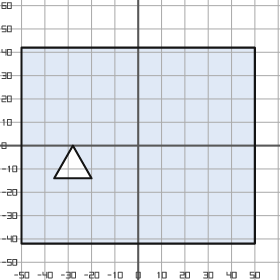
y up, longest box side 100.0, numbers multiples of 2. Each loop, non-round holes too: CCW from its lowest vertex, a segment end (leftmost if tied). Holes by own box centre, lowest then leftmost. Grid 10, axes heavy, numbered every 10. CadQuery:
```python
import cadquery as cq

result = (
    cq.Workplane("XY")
    .moveTo(-50.0, -42.0)
    .lineTo(50.0, -42.0)
    .lineTo(50.0, 42.0)
    .lineTo(-50.0, 42.0)
    .close()
    .moveTo(-36.0, -14.0)
    .lineTo(-20.0, -14.0)
    .lineTo(-28.0, 0.0)
    .close()
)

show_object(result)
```